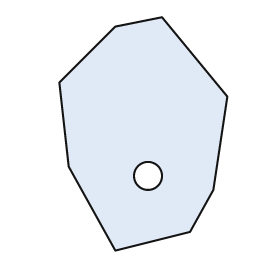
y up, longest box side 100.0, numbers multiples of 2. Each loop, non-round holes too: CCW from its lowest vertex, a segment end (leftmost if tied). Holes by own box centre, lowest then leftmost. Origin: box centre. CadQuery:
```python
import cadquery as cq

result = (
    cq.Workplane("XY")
    .moveTo(-12.0, -50.0)
    .lineTo(20.0, -42.0)
    .lineTo(30.0, -24.0)
    .lineTo(36.0, 16.0)
    .lineTo(8.0, 50.0)
    .lineTo(-12.0, 46.0)
    .lineTo(-36.0, 22.0)
    .lineTo(-32.0, -14.0)
    .close()
    .moveTo(2.0, -18.0)
    .circle(6.0)
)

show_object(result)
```